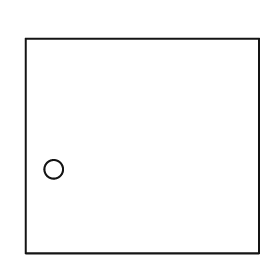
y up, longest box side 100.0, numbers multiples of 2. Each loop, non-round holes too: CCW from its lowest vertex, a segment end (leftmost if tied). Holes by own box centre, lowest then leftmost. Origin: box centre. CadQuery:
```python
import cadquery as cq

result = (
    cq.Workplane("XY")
    .moveTo(-50.0, -46.0)
    .lineTo(50.0, -46.0)
    .lineTo(50.0, 46.0)
    .lineTo(-50.0, 46.0)
    .close()
    .moveTo(-38.0, -10.0)
    .circle(4.0)
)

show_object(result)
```